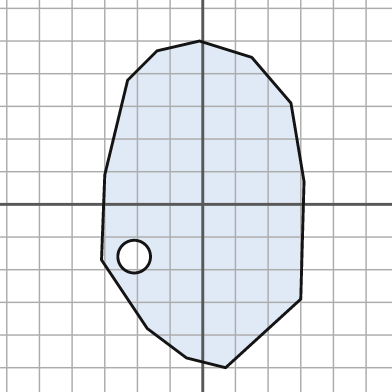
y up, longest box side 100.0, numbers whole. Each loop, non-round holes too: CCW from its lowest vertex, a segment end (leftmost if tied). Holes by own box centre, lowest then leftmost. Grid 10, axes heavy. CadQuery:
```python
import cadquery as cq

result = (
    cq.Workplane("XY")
    .moveTo(7.0, -50.0)
    .lineTo(30.0, -29.0)
    .lineTo(31.0, 7.0)
    .lineTo(27.0, 31.0)
    .lineTo(15.0, 45.0)
    .lineTo(-1.0, 50.0)
    .lineTo(-14.0, 47.0)
    .lineTo(-23.0, 38.0)
    .lineTo(-30.0, 9.0)
    .lineTo(-31.0, -17.0)
    .lineTo(-17.0, -38.0)
    .lineTo(-5.0, -47.0)
    .close()
    .moveTo(-21.0, -16.0)
    .circle(5.0)
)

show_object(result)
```